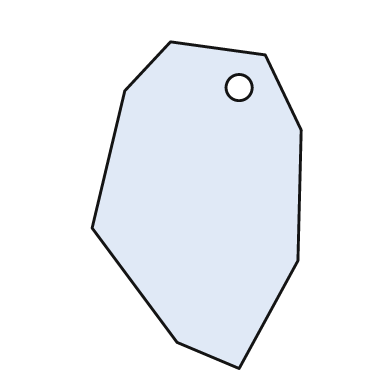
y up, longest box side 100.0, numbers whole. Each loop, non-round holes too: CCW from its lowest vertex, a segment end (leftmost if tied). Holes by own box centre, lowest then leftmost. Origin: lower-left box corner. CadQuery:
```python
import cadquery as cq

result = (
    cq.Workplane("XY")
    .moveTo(45.0, 0.0)
    .lineTo(63.0, 33.0)
    .lineTo(64.0, 73.0)
    .lineTo(53.0, 96.0)
    .lineTo(24.0, 100.0)
    .lineTo(10.0, 85.0)
    .lineTo(0.0, 43.0)
    .lineTo(26.0, 8.0)
    .close()
    .moveTo(45.0, 86.0)
    .circle(4.0)
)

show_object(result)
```